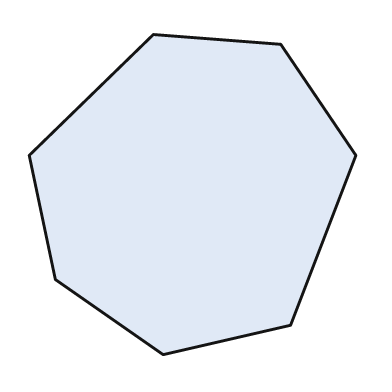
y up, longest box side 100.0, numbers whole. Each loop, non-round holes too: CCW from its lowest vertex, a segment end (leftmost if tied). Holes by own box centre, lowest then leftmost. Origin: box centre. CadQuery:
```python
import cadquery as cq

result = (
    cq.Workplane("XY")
    .moveTo(-9.0, -49.0)
    .lineTo(30.0, -40.0)
    .lineTo(50.0, 12.0)
    .lineTo(27.0, 46.0)
    .lineTo(-12.0, 49.0)
    .lineTo(-50.0, 12.0)
    .lineTo(-42.0, -26.0)
    .close()
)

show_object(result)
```